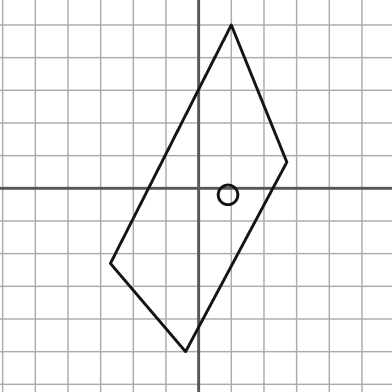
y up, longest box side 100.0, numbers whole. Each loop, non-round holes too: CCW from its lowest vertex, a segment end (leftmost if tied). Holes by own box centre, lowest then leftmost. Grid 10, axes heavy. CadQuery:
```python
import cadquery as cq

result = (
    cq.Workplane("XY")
    .moveTo(-4.0, -50.0)
    .lineTo(27.0, 8.0)
    .lineTo(10.0, 50.0)
    .lineTo(-27.0, -23.0)
    .close()
    .moveTo(9.0, -2.0)
    .circle(3.0)
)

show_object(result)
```